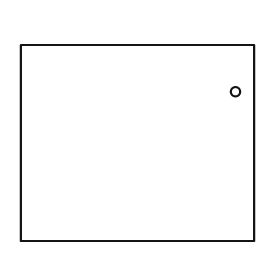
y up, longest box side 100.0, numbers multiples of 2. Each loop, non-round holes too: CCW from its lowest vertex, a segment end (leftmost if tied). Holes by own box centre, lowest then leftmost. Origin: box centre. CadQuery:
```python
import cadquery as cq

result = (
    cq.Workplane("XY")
    .moveTo(-50.0, -42.0)
    .lineTo(50.0, -42.0)
    .lineTo(50.0, 42.0)
    .lineTo(-50.0, 42.0)
    .close()
    .moveTo(42.0, 22.0)
    .circle(2.0)
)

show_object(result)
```